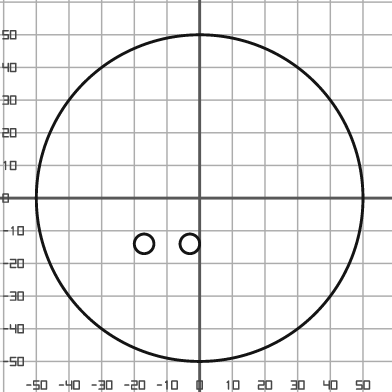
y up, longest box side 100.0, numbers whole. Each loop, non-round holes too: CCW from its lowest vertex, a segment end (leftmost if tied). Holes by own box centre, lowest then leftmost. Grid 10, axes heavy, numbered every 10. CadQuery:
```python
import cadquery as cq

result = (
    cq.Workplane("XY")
    .moveTo(0.0, 0.0)
    .circle(50.0)
    .moveTo(-17.0, -14.0)
    .circle(3.0)
    .moveTo(-3.0, -14.0)
    .circle(3.0)
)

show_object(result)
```